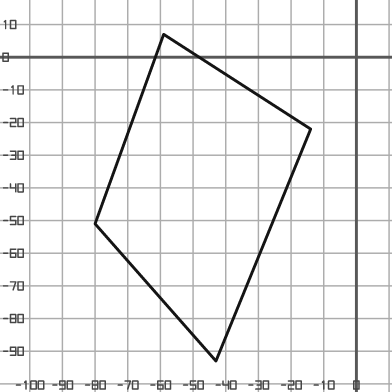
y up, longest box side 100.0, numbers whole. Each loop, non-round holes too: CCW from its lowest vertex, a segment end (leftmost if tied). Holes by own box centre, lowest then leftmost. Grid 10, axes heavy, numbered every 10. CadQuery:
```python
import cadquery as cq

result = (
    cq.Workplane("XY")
    .moveTo(-43.0, -93.0)
    .lineTo(-14.0, -22.0)
    .lineTo(-59.0, 7.0)
    .lineTo(-80.0, -51.0)
    .close()
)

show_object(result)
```